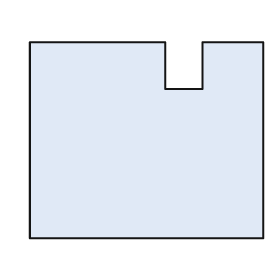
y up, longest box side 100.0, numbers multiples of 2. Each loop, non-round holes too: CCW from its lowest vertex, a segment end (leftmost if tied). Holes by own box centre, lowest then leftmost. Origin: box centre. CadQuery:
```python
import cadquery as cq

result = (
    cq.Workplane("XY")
    .moveTo(-50.0, -42.0)
    .lineTo(50.0, -42.0)
    .lineTo(50.0, 42.0)
    .lineTo(24.0, 42.0)
    .lineTo(24.0, 22.0)
    .lineTo(8.0, 22.0)
    .lineTo(8.0, 42.0)
    .lineTo(-50.0, 42.0)
    .close()
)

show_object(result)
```